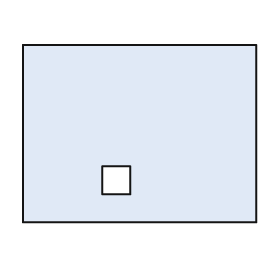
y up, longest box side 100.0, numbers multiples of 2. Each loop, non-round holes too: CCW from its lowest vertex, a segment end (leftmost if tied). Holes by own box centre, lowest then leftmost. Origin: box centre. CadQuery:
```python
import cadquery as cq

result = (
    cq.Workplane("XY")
    .moveTo(-50.0, -38.0)
    .lineTo(50.0, -38.0)
    .lineTo(50.0, 38.0)
    .lineTo(-50.0, 38.0)
    .close()
    .moveTo(-16.0, -26.0)
    .lineTo(-4.0, -26.0)
    .lineTo(-4.0, -14.0)
    .lineTo(-16.0, -14.0)
    .close()
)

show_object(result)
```